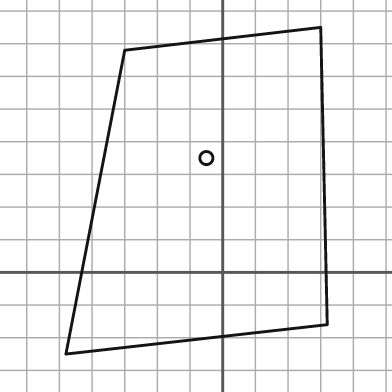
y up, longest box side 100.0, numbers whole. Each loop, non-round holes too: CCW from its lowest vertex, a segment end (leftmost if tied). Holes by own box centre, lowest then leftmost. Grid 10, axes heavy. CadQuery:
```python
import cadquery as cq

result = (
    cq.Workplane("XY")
    .moveTo(-48.0, -25.0)
    .lineTo(32.0, -16.0)
    .lineTo(30.0, 75.0)
    .lineTo(-30.0, 68.0)
    .close()
    .moveTo(-5.0, 35.0)
    .circle(2.0)
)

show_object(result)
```